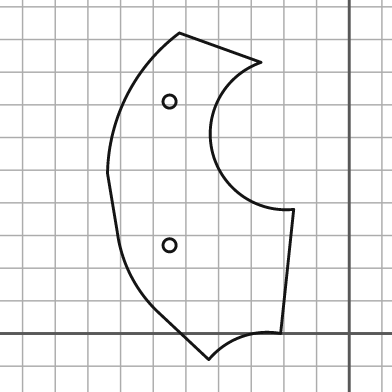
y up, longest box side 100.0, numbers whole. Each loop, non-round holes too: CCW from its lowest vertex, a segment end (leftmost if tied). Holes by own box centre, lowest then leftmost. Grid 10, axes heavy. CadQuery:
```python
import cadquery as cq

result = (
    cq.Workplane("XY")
    .moveTo(-43.0, -8.0)
    .threePointArc((-33.0, -1.0), (-21.0, 0.0))
    .lineTo(-17.0, 38.0)
    .threePointArc((-42.0, 56.0), (-27.0, 83.0))
    .lineTo(-52.0, 92.0)
    .threePointArc((-68.0, 73.0), (-74.0, 49.0))
    .lineTo(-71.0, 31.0)
    .threePointArc((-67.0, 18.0), (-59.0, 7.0))
    .close()
    .moveTo(-55.0, 27.0)
    .circle(2.0)
    .moveTo(-55.0, 71.0)
    .circle(2.0)
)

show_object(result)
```